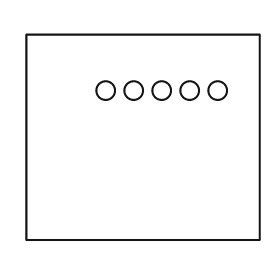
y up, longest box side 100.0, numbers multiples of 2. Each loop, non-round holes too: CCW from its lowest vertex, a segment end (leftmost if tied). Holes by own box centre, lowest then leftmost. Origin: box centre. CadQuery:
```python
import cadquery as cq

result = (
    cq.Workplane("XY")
    .moveTo(-50.0, -44.0)
    .lineTo(50.0, -44.0)
    .lineTo(50.0, 44.0)
    .lineTo(-50.0, 44.0)
    .close()
    .moveTo(-16.0, 20.0)
    .circle(4.0)
    .moveTo(-4.0, 20.0)
    .circle(4.0)
    .moveTo(8.0, 20.0)
    .circle(4.0)
    .moveTo(20.0, 20.0)
    .circle(4.0)
    .moveTo(32.0, 20.0)
    .circle(4.0)
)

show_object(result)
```